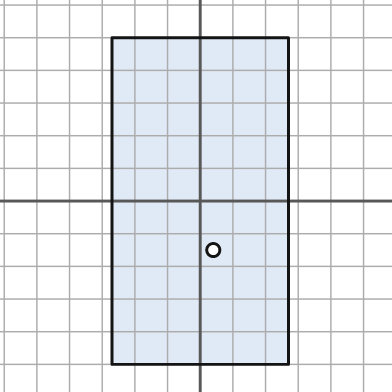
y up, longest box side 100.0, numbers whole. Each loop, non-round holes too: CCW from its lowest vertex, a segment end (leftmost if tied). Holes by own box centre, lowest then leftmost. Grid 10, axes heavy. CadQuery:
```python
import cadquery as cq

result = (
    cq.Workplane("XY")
    .moveTo(-27.0, -50.0)
    .lineTo(27.0, -50.0)
    .lineTo(27.0, 50.0)
    .lineTo(-27.0, 50.0)
    .close()
    .moveTo(4.0, -15.0)
    .circle(2.0)
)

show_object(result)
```